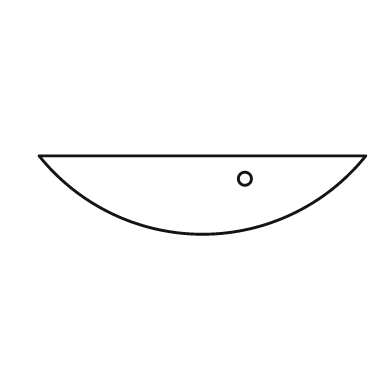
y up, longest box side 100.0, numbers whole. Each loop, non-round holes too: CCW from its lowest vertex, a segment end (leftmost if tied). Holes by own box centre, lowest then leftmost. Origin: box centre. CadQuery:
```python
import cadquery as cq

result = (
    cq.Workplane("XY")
    .moveTo(-50.0, 12.0)
    .threePointArc((0.0, -12.0), (50.0, 12.0))
    .close()
    .moveTo(13.0, 5.0)
    .circle(2.0)
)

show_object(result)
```